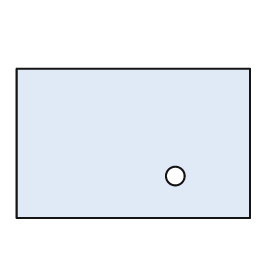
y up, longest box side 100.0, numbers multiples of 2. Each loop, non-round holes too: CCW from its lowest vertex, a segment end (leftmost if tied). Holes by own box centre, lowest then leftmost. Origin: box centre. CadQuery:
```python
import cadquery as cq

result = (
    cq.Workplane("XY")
    .moveTo(-50.0, -32.0)
    .lineTo(50.0, -32.0)
    .lineTo(50.0, 32.0)
    .lineTo(-50.0, 32.0)
    .close()
    .moveTo(18.0, -14.0)
    .circle(4.0)
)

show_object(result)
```